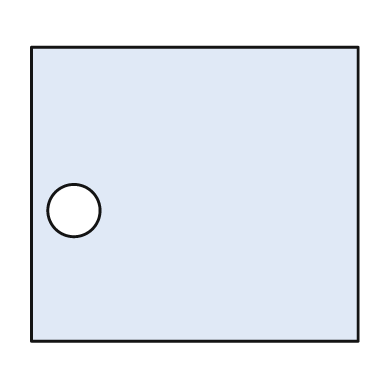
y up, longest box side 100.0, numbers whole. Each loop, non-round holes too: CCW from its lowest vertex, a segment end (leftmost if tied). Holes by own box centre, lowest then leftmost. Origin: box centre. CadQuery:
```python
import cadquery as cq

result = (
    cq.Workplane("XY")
    .moveTo(-50.0, -45.0)
    .lineTo(50.0, -45.0)
    .lineTo(50.0, 45.0)
    .lineTo(-50.0, 45.0)
    .close()
    .moveTo(-37.0, -5.0)
    .circle(8.0)
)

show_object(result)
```